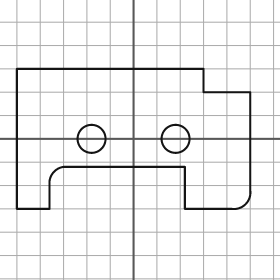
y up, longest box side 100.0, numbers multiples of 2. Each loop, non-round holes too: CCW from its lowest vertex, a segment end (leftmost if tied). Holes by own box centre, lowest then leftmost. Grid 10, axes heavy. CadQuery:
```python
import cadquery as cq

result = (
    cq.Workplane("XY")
    .moveTo(-50.0, -30.0)
    .lineTo(-36.0, -30.0)
    .lineTo(-36.0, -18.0)
    .threePointArc((-34.0, -14.0), (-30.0, -12.0))
    .lineTo(22.0, -12.0)
    .lineTo(22.0, -30.0)
    .lineTo(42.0, -30.0)
    .threePointArc((48.0, -28.0), (50.0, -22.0))
    .lineTo(50.0, 20.0)
    .lineTo(30.0, 20.0)
    .lineTo(30.0, 30.0)
    .lineTo(-50.0, 30.0)
    .close()
    .moveTo(-18.0, 0.0)
    .circle(6.0)
    .moveTo(18.0, 0.0)
    .circle(6.0)
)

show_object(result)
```